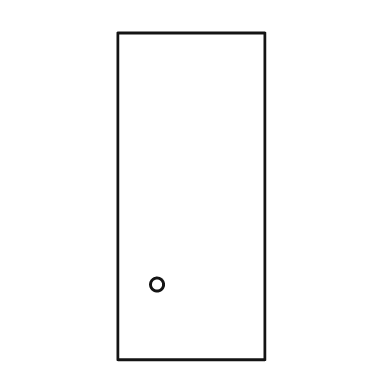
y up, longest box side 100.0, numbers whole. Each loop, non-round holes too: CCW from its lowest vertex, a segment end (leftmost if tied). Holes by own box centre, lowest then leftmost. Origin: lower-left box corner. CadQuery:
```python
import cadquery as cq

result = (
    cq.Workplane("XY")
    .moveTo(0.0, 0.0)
    .lineTo(45.0, 0.0)
    .lineTo(45.0, 100.0)
    .lineTo(0.0, 100.0)
    .close()
    .moveTo(12.0, 23.0)
    .circle(2.0)
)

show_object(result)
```